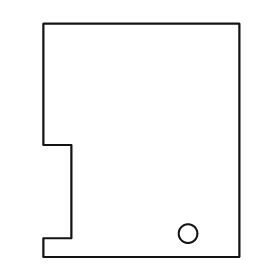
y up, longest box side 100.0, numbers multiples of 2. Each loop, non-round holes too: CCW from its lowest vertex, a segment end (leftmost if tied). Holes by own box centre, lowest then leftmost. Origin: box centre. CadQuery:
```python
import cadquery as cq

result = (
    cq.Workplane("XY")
    .moveTo(-42.0, -50.0)
    .lineTo(42.0, -50.0)
    .lineTo(42.0, 50.0)
    .lineTo(-42.0, 50.0)
    .lineTo(-42.0, -2.0)
    .lineTo(-30.0, -2.0)
    .lineTo(-30.0, -42.0)
    .lineTo(-42.0, -42.0)
    .close()
    .moveTo(20.0, -40.0)
    .circle(4.0)
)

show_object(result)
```